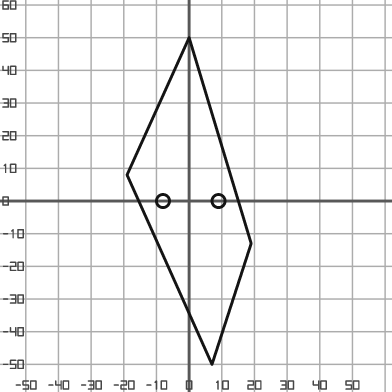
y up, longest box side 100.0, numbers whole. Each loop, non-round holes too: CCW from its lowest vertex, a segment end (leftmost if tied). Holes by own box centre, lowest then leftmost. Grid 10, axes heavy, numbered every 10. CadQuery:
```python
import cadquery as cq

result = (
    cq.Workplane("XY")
    .moveTo(7.0, -50.0)
    .lineTo(19.0, -13.0)
    .lineTo(0.0, 50.0)
    .lineTo(-19.0, 8.0)
    .close()
    .moveTo(-8.0, 0.0)
    .circle(2.0)
    .moveTo(9.0, 0.0)
    .circle(2.0)
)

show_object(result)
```